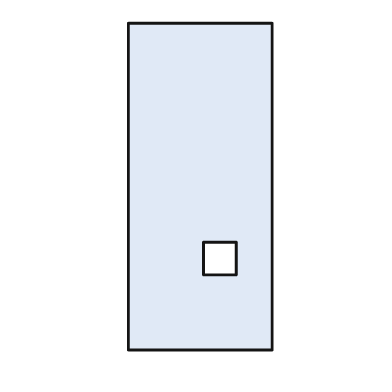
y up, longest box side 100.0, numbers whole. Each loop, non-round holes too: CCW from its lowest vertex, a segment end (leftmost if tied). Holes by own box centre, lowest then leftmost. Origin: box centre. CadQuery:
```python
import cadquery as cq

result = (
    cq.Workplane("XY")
    .moveTo(-22.0, -50.0)
    .lineTo(22.0, -50.0)
    .lineTo(22.0, 50.0)
    .lineTo(-22.0, 50.0)
    .close()
    .moveTo(1.0, -27.0)
    .lineTo(11.0, -27.0)
    .lineTo(11.0, -17.0)
    .lineTo(1.0, -17.0)
    .close()
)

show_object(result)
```